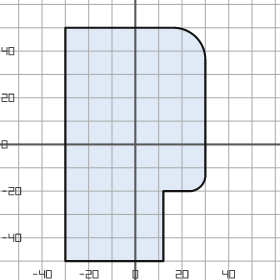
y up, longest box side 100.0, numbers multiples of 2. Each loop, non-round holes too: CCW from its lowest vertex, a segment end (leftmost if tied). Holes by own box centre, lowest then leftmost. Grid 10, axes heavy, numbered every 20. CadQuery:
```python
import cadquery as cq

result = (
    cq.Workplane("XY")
    .moveTo(-30.0, -50.0)
    .lineTo(12.0, -50.0)
    .lineTo(12.0, -20.0)
    .lineTo(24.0, -20.0)
    .threePointArc((28.0, -18.0), (30.0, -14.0))
    .lineTo(30.0, 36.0)
    .threePointArc((26.0, 46.0), (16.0, 50.0))
    .lineTo(-30.0, 50.0)
    .close()
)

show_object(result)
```